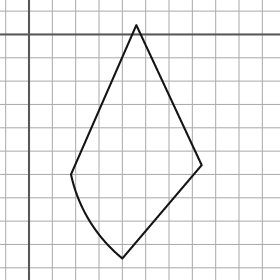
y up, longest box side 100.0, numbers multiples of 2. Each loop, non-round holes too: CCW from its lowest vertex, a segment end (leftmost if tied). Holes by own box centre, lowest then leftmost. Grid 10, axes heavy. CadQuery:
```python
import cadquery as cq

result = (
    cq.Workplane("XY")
    .moveTo(40.0, -96.0)
    .lineTo(74.0, -56.0)
    .lineTo(46.0, 4.0)
    .lineTo(18.0, -60.0)
    .threePointArc((26.0, -80.0), (40.0, -96.0))
    .close()
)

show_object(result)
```